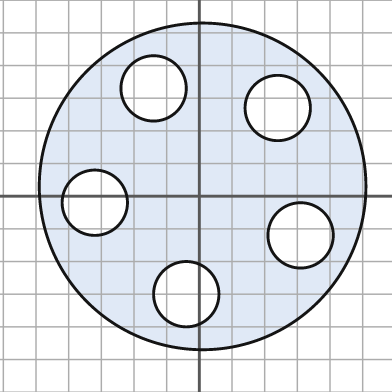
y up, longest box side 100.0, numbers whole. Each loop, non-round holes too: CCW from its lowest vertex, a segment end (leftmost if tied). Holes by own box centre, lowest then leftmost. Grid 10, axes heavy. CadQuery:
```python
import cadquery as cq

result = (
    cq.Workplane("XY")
    .moveTo(1.0, 3.0)
    .circle(50.0)
    .moveTo(-4.0, -30.0)
    .circle(10.0)
    .moveTo(31.0, -12.0)
    .circle(10.0)
    .moveTo(-32.0, -2.0)
    .circle(10.0)
    .moveTo(24.0, 27.0)
    .circle(10.0)
    .moveTo(-14.0, 33.0)
    .circle(10.0)
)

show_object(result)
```